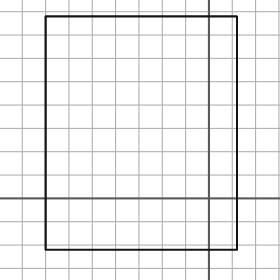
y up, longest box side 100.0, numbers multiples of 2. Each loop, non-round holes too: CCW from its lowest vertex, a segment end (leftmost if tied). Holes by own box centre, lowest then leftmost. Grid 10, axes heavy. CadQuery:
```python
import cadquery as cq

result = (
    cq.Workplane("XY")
    .moveTo(-70.0, -22.0)
    .lineTo(12.0, -22.0)
    .lineTo(12.0, 78.0)
    .lineTo(-70.0, 78.0)
    .close()
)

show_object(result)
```